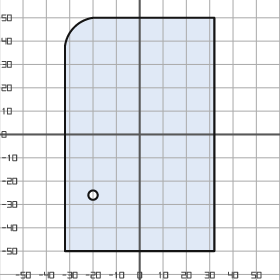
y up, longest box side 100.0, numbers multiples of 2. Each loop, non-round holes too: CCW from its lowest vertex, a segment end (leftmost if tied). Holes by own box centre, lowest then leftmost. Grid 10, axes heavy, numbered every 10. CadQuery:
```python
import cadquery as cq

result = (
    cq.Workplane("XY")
    .moveTo(-32.0, -50.0)
    .lineTo(32.0, -50.0)
    .lineTo(32.0, 50.0)
    .lineTo(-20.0, 50.0)
    .threePointArc((-28.0, 46.0), (-32.0, 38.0))
    .close()
    .moveTo(-20.0, -26.0)
    .circle(2.0)
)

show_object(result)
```